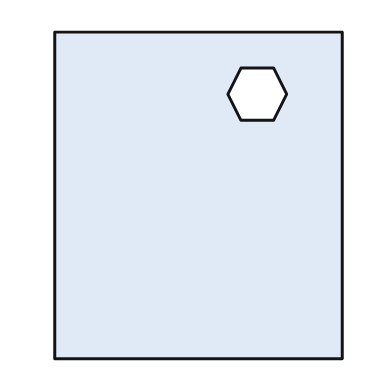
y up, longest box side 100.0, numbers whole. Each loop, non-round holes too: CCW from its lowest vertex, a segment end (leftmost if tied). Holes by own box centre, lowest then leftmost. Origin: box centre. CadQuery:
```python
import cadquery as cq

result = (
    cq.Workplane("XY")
    .moveTo(-44.0, -50.0)
    .lineTo(44.0, -50.0)
    .lineTo(44.0, 50.0)
    .lineTo(-44.0, 50.0)
    .close()
    .moveTo(13.0, 23.0)
    .lineTo(23.0, 23.0)
    .lineTo(27.0, 31.0)
    .lineTo(23.0, 39.0)
    .lineTo(13.0, 39.0)
    .lineTo(9.0, 31.0)
    .close()
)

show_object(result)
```